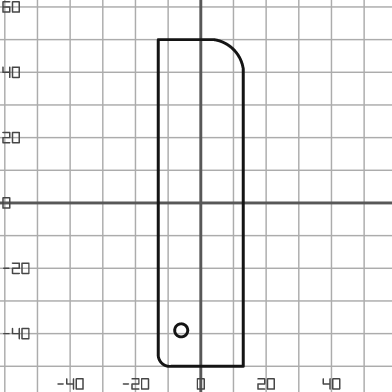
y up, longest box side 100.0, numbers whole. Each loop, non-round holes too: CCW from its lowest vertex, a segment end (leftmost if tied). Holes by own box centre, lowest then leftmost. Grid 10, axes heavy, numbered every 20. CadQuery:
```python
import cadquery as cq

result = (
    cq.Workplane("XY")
    .moveTo(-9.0, -50.0)
    .lineTo(13.0, -50.0)
    .lineTo(13.0, 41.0)
    .threePointArc((10.0, 47.0), (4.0, 50.0))
    .lineTo(-13.0, 50.0)
    .lineTo(-13.0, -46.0)
    .threePointArc((-12.0, -49.0), (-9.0, -50.0))
    .close()
    .moveTo(-6.0, -39.0)
    .circle(2.0)
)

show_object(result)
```